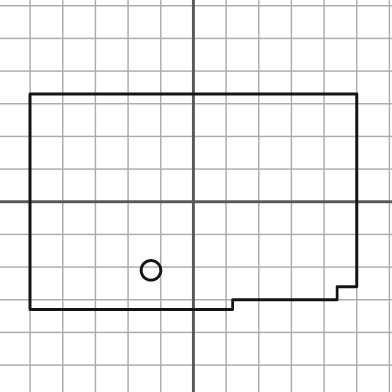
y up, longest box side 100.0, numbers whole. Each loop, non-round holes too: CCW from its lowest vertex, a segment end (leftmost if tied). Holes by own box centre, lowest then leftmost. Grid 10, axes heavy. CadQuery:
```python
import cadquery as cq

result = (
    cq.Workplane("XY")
    .moveTo(-50.0, -33.0)
    .lineTo(12.0, -33.0)
    .lineTo(12.0, -30.0)
    .lineTo(44.0, -30.0)
    .lineTo(44.0, -26.0)
    .lineTo(50.0, -26.0)
    .lineTo(50.0, 33.0)
    .lineTo(-50.0, 33.0)
    .close()
    .moveTo(-13.0, -21.0)
    .circle(3.0)
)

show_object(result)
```